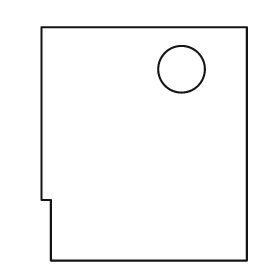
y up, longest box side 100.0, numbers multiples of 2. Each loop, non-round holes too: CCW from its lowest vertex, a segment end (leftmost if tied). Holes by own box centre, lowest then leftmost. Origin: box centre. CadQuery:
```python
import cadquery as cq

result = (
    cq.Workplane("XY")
    .moveTo(-40.0, -50.0)
    .lineTo(44.0, -50.0)
    .lineTo(44.0, 50.0)
    .lineTo(-44.0, 50.0)
    .lineTo(-44.0, -24.0)
    .lineTo(-40.0, -24.0)
    .close()
    .moveTo(16.0, 32.0)
    .circle(10.0)
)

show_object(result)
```